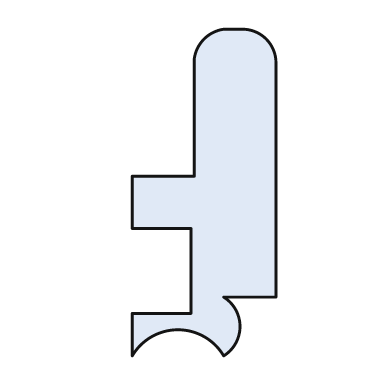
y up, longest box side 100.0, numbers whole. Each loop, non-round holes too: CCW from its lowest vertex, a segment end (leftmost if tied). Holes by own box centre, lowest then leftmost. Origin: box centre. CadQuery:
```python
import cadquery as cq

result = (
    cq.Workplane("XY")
    .moveTo(-22.0, -50.0)
    .threePointArc((-8.0, -42.0), (6.0, -50.0))
    .threePointArc((11.0, -41.0), (6.0, -32.0))
    .lineTo(22.0, -32.0)
    .lineTo(22.0, 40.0)
    .threePointArc((19.0, 47.0), (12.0, 50.0))
    .lineTo(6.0, 50.0)
    .threePointArc((0.0, 47.0), (-3.0, 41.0))
    .lineTo(-3.0, 5.0)
    .lineTo(-22.0, 5.0)
    .lineTo(-22.0, -11.0)
    .lineTo(-4.0, -11.0)
    .lineTo(-4.0, -37.0)
    .lineTo(-22.0, -37.0)
    .close()
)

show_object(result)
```